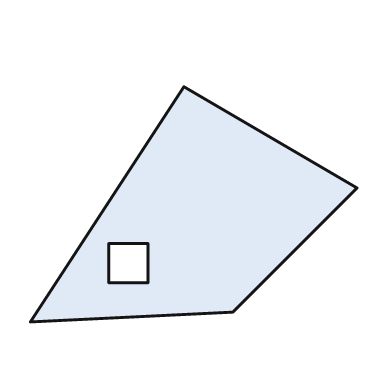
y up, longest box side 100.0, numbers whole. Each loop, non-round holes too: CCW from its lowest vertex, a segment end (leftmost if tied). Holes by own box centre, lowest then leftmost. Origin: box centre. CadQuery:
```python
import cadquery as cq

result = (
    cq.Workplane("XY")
    .moveTo(-50.0, -36.0)
    .lineTo(12.0, -33.0)
    .lineTo(50.0, 5.0)
    .lineTo(-3.0, 36.0)
    .close()
    .moveTo(-26.0, -24.0)
    .lineTo(-14.0, -24.0)
    .lineTo(-14.0, -12.0)
    .lineTo(-26.0, -12.0)
    .close()
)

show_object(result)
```